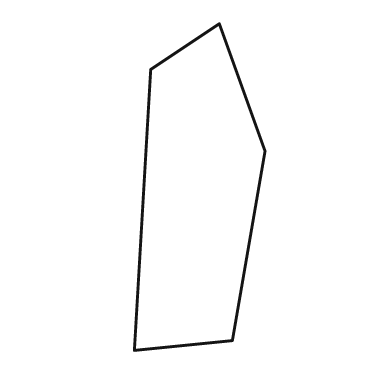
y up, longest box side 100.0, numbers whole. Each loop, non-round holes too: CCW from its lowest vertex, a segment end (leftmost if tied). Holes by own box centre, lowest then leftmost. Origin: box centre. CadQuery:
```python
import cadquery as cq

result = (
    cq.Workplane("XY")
    .moveTo(-20.0, -50.0)
    .lineTo(10.0, -47.0)
    .lineTo(20.0, 11.0)
    .lineTo(6.0, 50.0)
    .lineTo(-15.0, 36.0)
    .close()
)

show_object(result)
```